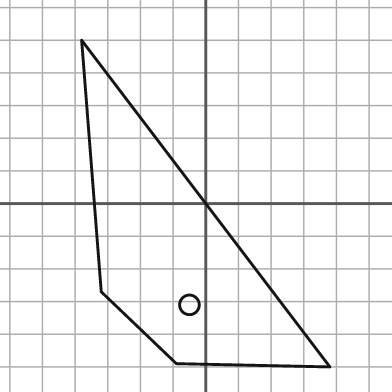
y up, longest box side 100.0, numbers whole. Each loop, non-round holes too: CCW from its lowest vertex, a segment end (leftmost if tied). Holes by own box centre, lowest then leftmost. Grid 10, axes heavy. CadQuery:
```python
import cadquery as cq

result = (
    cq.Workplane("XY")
    .moveTo(38.0, -50.0)
    .lineTo(-38.0, 50.0)
    .lineTo(-32.0, -27.0)
    .lineTo(-9.0, -49.0)
    .close()
    .moveTo(-5.0, -31.0)
    .circle(3.0)
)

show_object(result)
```